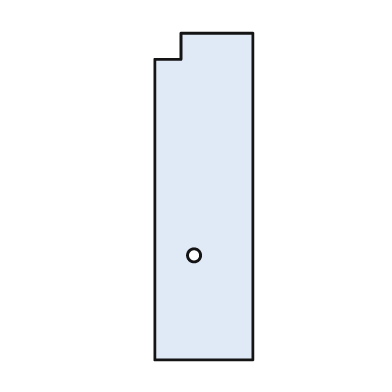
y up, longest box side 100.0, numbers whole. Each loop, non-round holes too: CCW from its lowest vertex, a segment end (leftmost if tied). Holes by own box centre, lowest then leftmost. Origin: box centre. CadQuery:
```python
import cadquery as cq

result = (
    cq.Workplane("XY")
    .moveTo(-15.0, -50.0)
    .lineTo(15.0, -50.0)
    .lineTo(15.0, 50.0)
    .lineTo(-7.0, 50.0)
    .lineTo(-7.0, 42.0)
    .lineTo(-15.0, 42.0)
    .close()
    .moveTo(-3.0, -18.0)
    .circle(2.0)
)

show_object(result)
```